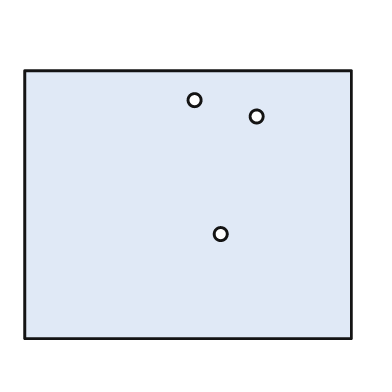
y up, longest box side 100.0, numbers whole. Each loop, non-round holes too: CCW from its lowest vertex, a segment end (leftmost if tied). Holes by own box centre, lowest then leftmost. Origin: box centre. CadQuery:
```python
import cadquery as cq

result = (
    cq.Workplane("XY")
    .moveTo(-50.0, -41.0)
    .lineTo(50.0, -41.0)
    .lineTo(50.0, 41.0)
    .lineTo(-50.0, 41.0)
    .close()
    .moveTo(10.0, -9.0)
    .circle(2.0)
    .moveTo(21.0, 27.0)
    .circle(2.0)
    .moveTo(2.0, 32.0)
    .circle(2.0)
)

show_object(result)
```